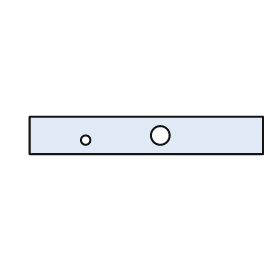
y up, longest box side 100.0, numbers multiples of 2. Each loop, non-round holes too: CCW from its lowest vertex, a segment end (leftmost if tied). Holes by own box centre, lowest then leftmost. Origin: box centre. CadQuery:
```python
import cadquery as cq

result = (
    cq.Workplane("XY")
    .moveTo(-50.0, -8.0)
    .lineTo(50.0, -8.0)
    .lineTo(50.0, 8.0)
    .lineTo(-50.0, 8.0)
    .close()
    .moveTo(-26.0, -2.0)
    .circle(2.0)
    .moveTo(6.0, 0.0)
    .circle(4.0)
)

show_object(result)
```